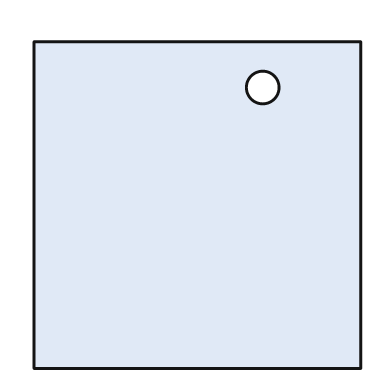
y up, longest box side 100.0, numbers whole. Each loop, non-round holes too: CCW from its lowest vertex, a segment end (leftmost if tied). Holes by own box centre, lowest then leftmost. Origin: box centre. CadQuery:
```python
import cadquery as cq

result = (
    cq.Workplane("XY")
    .moveTo(-50.0, -50.0)
    .lineTo(50.0, -50.0)
    .lineTo(50.0, 50.0)
    .lineTo(-50.0, 50.0)
    .close()
    .moveTo(20.0, 36.0)
    .circle(5.0)
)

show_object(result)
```